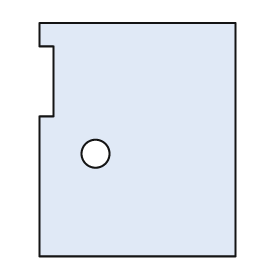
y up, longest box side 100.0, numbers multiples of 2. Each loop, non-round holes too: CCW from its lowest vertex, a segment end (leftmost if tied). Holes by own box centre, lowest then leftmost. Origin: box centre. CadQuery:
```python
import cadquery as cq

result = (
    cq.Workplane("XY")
    .moveTo(-42.0, -50.0)
    .lineTo(42.0, -50.0)
    .lineTo(42.0, 50.0)
    .lineTo(-42.0, 50.0)
    .lineTo(-42.0, 40.0)
    .lineTo(-36.0, 40.0)
    .lineTo(-36.0, 10.0)
    .lineTo(-42.0, 10.0)
    .close()
    .moveTo(-18.0, -6.0)
    .circle(6.0)
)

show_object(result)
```